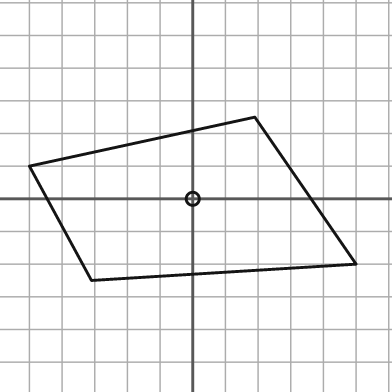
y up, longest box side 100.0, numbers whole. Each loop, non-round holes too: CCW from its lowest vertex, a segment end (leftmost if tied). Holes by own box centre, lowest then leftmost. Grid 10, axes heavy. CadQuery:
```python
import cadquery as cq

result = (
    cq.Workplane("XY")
    .moveTo(-31.0, -25.0)
    .lineTo(50.0, -20.0)
    .lineTo(19.0, 25.0)
    .lineTo(-50.0, 10.0)
    .close()
    .moveTo(0.0, 0.0)
    .circle(2.0)
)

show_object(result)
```